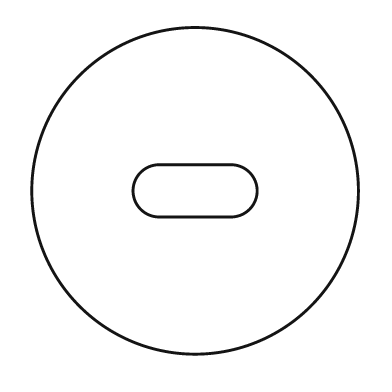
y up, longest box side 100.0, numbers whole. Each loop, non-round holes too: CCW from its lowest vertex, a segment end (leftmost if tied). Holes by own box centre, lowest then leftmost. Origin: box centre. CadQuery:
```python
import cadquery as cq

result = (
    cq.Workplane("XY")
    .moveTo(0.0, 0.0)
    .circle(50.0)
    .moveTo(-11.0, -8.0)
    .lineTo(11.0, -8.0)
    .threePointArc((19.0, 0.0), (11.0, 8.0))
    .lineTo(-11.0, 8.0)
    .threePointArc((-19.0, 0.0), (-11.0, -8.0))
    .close()
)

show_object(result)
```